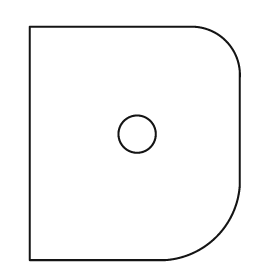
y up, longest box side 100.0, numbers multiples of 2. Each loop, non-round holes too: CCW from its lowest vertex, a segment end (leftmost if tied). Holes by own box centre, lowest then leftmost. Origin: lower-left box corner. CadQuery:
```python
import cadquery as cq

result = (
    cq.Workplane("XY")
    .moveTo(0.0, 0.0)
    .lineTo(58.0, 0.0)
    .threePointArc((80.0, 10.0), (90.0, 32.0))
    .lineTo(90.0, 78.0)
    .threePointArc((84.0, 94.0), (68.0, 100.0))
    .lineTo(0.0, 100.0)
    .close()
    .moveTo(46.0, 54.0)
    .circle(8.0)
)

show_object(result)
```